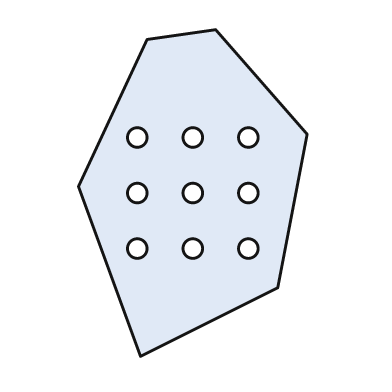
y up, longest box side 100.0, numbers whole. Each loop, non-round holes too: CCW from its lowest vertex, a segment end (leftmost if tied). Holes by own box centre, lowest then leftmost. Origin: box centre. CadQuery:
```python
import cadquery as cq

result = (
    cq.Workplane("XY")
    .moveTo(-16.0, -50.0)
    .lineTo(26.0, -29.0)
    .lineTo(35.0, 18.0)
    .lineTo(7.0, 50.0)
    .lineTo(-14.0, 47.0)
    .lineTo(-35.0, 2.0)
    .close()
    .moveTo(-17.0, -17.0)
    .circle(3.0)
    .moveTo(0.0, -17.0)
    .circle(3.0)
    .moveTo(17.0, -17.0)
    .circle(3.0)
    .moveTo(-17.0, 0.0)
    .circle(3.0)
    .moveTo(0.0, 0.0)
    .circle(3.0)
    .moveTo(17.0, 0.0)
    .circle(3.0)
    .moveTo(-17.0, 17.0)
    .circle(3.0)
    .moveTo(0.0, 17.0)
    .circle(3.0)
    .moveTo(17.0, 17.0)
    .circle(3.0)
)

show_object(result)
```